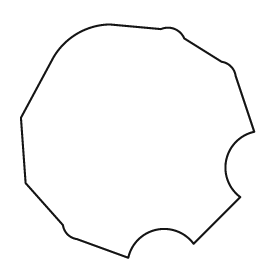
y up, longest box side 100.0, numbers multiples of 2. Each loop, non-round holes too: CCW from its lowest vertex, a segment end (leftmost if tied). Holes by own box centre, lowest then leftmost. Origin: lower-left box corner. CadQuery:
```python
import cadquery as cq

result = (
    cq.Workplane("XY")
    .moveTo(46.0, 0.0)
    .threePointArc((58.0, 12.0), (74.0, 6.0))
    .lineTo(94.0, 26.0)
    .threePointArc((88.0, 42.0), (100.0, 54.0))
    .lineTo(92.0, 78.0)
    .threePointArc((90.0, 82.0), (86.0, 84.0))
    .lineTo(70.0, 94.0)
    .threePointArc((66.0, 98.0), (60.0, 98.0))
    .lineTo(38.0, 100.0)
    .threePointArc((24.0, 96.0), (14.0, 86.0))
    .lineTo(0.0, 60.0)
    .lineTo(2.0, 32.0)
    .lineTo(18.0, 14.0)
    .threePointArc((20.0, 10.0), (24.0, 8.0))
    .close()
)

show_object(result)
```